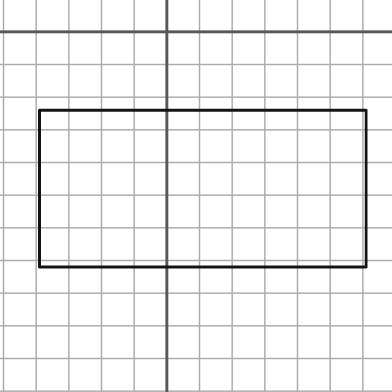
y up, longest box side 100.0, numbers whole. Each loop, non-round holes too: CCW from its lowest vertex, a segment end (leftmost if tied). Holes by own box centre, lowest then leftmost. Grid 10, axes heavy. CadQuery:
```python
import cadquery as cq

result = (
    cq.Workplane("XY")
    .moveTo(-39.0, -72.0)
    .lineTo(61.0, -72.0)
    .lineTo(61.0, -24.0)
    .lineTo(-39.0, -24.0)
    .close()
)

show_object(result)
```